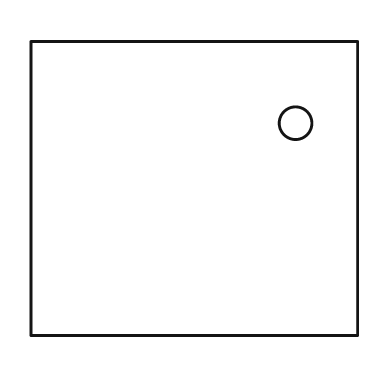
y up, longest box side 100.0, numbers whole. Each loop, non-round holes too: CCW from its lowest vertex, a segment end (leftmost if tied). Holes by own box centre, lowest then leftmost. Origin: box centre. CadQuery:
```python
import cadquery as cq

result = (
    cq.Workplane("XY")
    .moveTo(-50.0, -45.0)
    .lineTo(50.0, -45.0)
    .lineTo(50.0, 45.0)
    .lineTo(-50.0, 45.0)
    .close()
    .moveTo(31.0, 20.0)
    .circle(5.0)
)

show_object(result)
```